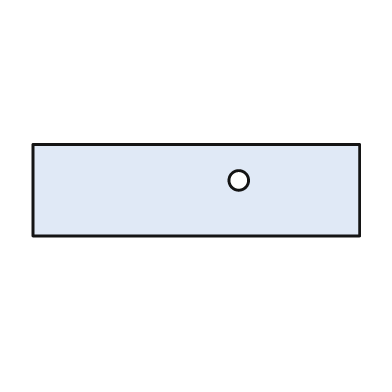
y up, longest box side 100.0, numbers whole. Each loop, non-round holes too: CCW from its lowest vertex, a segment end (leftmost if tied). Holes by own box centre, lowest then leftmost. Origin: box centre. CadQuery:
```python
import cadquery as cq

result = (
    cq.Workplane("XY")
    .moveTo(-50.0, -14.0)
    .lineTo(50.0, -14.0)
    .lineTo(50.0, 14.0)
    .lineTo(-50.0, 14.0)
    .close()
    .moveTo(13.0, 3.0)
    .circle(3.0)
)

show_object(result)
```